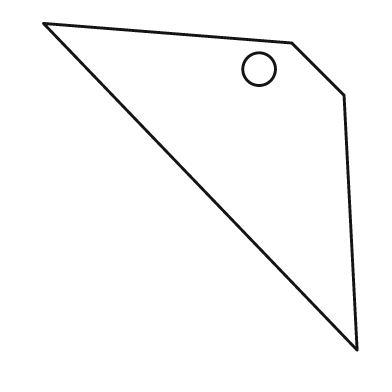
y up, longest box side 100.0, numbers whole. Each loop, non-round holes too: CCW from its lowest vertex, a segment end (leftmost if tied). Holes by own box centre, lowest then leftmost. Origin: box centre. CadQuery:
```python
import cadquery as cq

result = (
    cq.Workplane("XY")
    .moveTo(48.0, -50.0)
    .lineTo(44.0, 28.0)
    .lineTo(28.0, 44.0)
    .lineTo(-48.0, 50.0)
    .close()
    .moveTo(18.0, 36.0)
    .circle(5.0)
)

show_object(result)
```